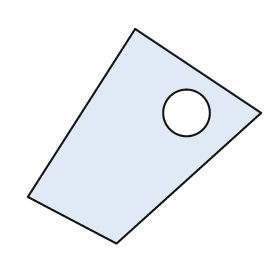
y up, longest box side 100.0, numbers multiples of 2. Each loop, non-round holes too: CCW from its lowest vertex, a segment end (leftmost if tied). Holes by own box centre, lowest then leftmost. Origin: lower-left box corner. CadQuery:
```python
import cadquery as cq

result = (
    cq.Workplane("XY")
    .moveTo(38.0, 0.0)
    .lineTo(100.0, 56.0)
    .lineTo(46.0, 92.0)
    .lineTo(0.0, 20.0)
    .close()
    .moveTo(68.0, 56.0)
    .circle(10.0)
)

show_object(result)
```